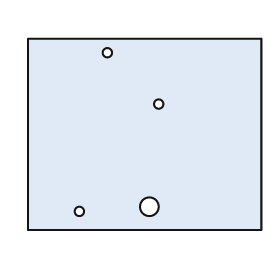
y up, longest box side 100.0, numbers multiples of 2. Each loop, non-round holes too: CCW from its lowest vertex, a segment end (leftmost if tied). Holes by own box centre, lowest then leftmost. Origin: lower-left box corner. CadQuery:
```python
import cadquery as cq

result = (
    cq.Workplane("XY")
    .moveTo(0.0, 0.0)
    .lineTo(100.0, 0.0)
    .lineTo(100.0, 82.0)
    .lineTo(0.0, 82.0)
    .close()
    .moveTo(22.0, 8.0)
    .circle(2.0)
    .moveTo(52.0, 10.0)
    .circle(4.0)
    .moveTo(56.0, 54.0)
    .circle(2.0)
    .moveTo(34.0, 76.0)
    .circle(2.0)
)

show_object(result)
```